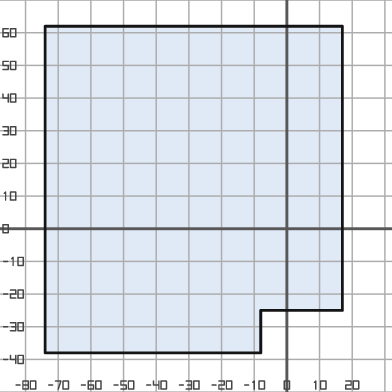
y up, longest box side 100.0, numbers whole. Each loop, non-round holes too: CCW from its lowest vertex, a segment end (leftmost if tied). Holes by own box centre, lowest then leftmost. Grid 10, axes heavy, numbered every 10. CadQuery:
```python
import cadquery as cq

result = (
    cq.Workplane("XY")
    .moveTo(-74.0, -38.0)
    .lineTo(-8.0, -38.0)
    .lineTo(-8.0, -25.0)
    .lineTo(17.0, -25.0)
    .lineTo(17.0, 62.0)
    .lineTo(-74.0, 62.0)
    .close()
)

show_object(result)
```